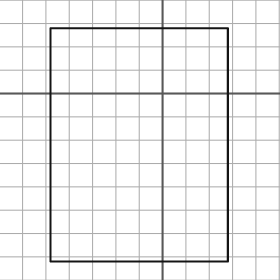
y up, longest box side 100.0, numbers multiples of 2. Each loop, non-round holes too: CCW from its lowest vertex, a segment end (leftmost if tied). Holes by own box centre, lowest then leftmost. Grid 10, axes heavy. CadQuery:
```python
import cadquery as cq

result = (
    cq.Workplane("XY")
    .moveTo(-48.0, -72.0)
    .lineTo(28.0, -72.0)
    .lineTo(28.0, 28.0)
    .lineTo(-48.0, 28.0)
    .close()
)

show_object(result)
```